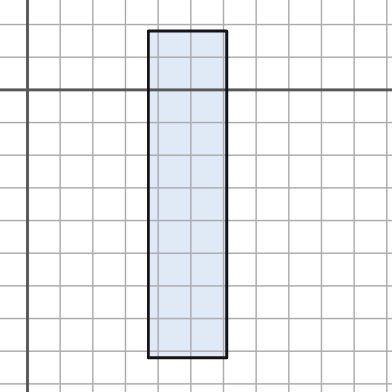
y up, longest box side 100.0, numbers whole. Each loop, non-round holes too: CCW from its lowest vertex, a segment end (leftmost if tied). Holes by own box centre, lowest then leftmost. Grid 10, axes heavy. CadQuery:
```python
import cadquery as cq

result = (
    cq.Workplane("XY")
    .moveTo(37.0, -82.0)
    .lineTo(61.0, -82.0)
    .lineTo(61.0, 18.0)
    .lineTo(37.0, 18.0)
    .close()
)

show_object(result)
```